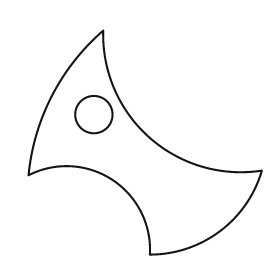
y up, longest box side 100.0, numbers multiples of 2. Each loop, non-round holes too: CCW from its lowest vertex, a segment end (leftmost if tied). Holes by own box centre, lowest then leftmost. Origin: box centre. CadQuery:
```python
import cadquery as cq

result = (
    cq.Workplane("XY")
    .moveTo(2.0, -48.0)
    .threePointArc((32.0, -38.0), (50.0, -12.0))
    .threePointArc((2.0, 2.0), (-18.0, 48.0))
    .threePointArc((-40.0, 20.0), (-50.0, -14.0))
    .threePointArc((-14.0, -16.0), (2.0, -48.0))
    .close()
    .moveTo(-22.0, 12.0)
    .circle(8.0)
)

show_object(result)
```